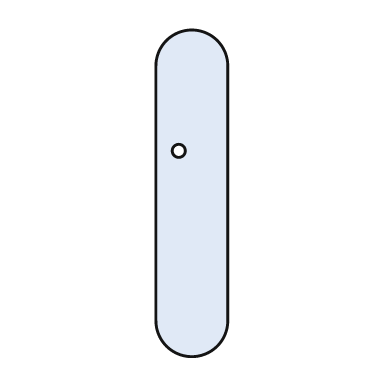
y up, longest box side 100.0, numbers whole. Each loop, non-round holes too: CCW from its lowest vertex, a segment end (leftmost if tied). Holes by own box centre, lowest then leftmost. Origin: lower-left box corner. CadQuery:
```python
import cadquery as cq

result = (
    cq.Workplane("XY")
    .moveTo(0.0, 11.0)
    .threePointArc((11.0, 0.0), (22.0, 11.0))
    .lineTo(22.0, 89.0)
    .threePointArc((11.0, 100.0), (0.0, 89.0))
    .close()
    .moveTo(7.0, 63.0)
    .circle(2.0)
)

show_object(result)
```